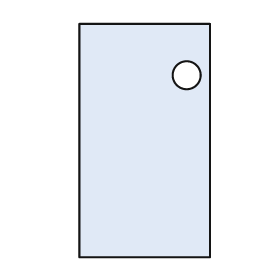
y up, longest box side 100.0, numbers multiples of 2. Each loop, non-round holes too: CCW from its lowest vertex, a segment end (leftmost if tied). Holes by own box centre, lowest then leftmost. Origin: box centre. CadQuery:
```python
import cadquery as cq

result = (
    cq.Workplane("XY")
    .moveTo(-28.0, -50.0)
    .lineTo(28.0, -50.0)
    .lineTo(28.0, 50.0)
    .lineTo(-28.0, 50.0)
    .close()
    .moveTo(18.0, 28.0)
    .circle(6.0)
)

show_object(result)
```